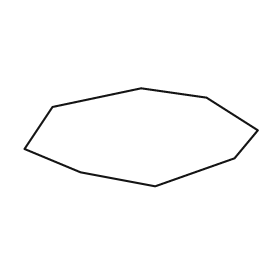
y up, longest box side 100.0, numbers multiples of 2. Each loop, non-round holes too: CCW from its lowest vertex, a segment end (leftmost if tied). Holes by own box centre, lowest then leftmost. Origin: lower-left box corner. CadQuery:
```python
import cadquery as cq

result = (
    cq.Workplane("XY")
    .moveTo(56.0, 0.0)
    .lineTo(90.0, 12.0)
    .lineTo(100.0, 24.0)
    .lineTo(78.0, 38.0)
    .lineTo(50.0, 42.0)
    .lineTo(12.0, 34.0)
    .lineTo(0.0, 16.0)
    .lineTo(24.0, 6.0)
    .close()
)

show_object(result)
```